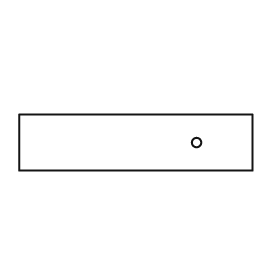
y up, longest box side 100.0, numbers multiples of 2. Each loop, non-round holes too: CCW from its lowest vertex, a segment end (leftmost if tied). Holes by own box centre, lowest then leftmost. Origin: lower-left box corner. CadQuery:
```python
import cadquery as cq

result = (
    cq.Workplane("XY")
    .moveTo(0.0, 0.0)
    .lineTo(100.0, 0.0)
    .lineTo(100.0, 24.0)
    .lineTo(0.0, 24.0)
    .close()
    .moveTo(76.0, 12.0)
    .circle(2.0)
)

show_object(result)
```